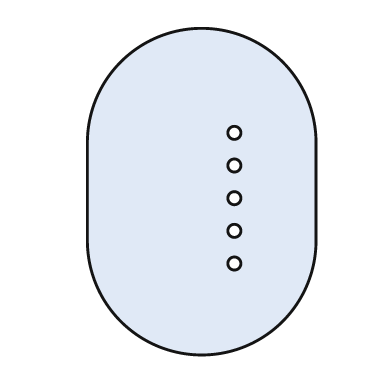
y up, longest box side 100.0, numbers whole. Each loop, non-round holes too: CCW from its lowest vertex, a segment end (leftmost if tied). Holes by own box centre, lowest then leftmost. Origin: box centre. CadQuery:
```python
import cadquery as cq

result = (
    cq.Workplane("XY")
    .moveTo(-35.0, -15.0)
    .threePointArc((0.0, -50.0), (35.0, -15.0))
    .lineTo(35.0, 15.0)
    .threePointArc((0.0, 50.0), (-35.0, 15.0))
    .close()
    .moveTo(10.0, -22.0)
    .circle(2.0)
    .moveTo(10.0, -12.0)
    .circle(2.0)
    .moveTo(10.0, -2.0)
    .circle(2.0)
    .moveTo(10.0, 8.0)
    .circle(2.0)
    .moveTo(10.0, 18.0)
    .circle(2.0)
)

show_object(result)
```